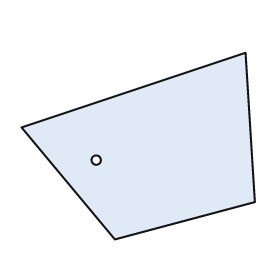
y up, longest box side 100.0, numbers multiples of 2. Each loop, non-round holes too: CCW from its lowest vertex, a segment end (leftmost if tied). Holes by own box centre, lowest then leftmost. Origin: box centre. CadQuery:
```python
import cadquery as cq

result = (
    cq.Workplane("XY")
    .moveTo(-10.0, -40.0)
    .lineTo(50.0, -24.0)
    .lineTo(46.0, 40.0)
    .lineTo(-50.0, 8.0)
    .close()
    .moveTo(-18.0, -6.0)
    .circle(2.0)
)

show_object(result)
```